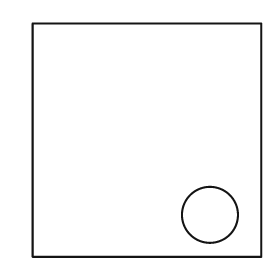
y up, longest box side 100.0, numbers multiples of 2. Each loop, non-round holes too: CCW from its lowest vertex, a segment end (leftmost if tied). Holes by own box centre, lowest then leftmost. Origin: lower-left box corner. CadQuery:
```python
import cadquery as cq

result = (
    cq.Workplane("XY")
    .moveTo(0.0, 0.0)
    .lineTo(98.0, 0.0)
    .lineTo(98.0, 100.0)
    .lineTo(0.0, 100.0)
    .close()
    .moveTo(76.0, 18.0)
    .circle(12.0)
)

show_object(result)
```